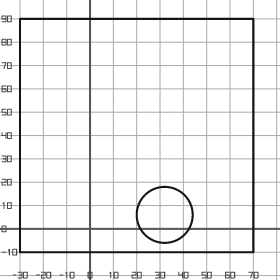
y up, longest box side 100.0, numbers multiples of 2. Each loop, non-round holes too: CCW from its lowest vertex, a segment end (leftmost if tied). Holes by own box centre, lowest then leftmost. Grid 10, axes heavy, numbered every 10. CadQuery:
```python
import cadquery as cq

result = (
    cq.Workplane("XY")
    .moveTo(-30.0, -10.0)
    .lineTo(70.0, -10.0)
    .lineTo(70.0, 90.0)
    .lineTo(-30.0, 90.0)
    .close()
    .moveTo(32.0, 6.0)
    .circle(12.0)
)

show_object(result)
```